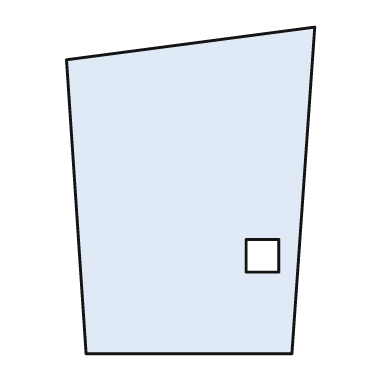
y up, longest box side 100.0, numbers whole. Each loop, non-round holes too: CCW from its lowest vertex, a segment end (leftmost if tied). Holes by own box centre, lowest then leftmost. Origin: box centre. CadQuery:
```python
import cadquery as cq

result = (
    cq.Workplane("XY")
    .moveTo(-32.0, -50.0)
    .lineTo(31.0, -50.0)
    .lineTo(38.0, 50.0)
    .lineTo(-38.0, 40.0)
    .close()
    .moveTo(17.0, -25.0)
    .lineTo(27.0, -25.0)
    .lineTo(27.0, -15.0)
    .lineTo(17.0, -15.0)
    .close()
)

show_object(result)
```